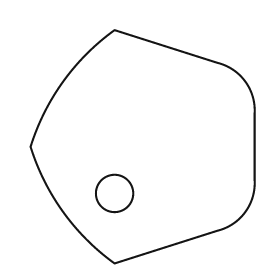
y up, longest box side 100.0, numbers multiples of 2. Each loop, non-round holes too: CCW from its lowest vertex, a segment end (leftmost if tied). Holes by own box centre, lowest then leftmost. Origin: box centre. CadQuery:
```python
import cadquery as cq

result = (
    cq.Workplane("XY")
    .moveTo(-12.0, -50.0)
    .lineTo(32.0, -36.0)
    .threePointArc((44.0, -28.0), (48.0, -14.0))
    .lineTo(48.0, 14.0)
    .threePointArc((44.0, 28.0), (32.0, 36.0))
    .lineTo(-12.0, 50.0)
    .threePointArc((-34.0, 28.0), (-48.0, 0.0))
    .threePointArc((-34.0, -28.0), (-12.0, -50.0))
    .close()
    .moveTo(-12.0, -20.0)
    .circle(8.0)
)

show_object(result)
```